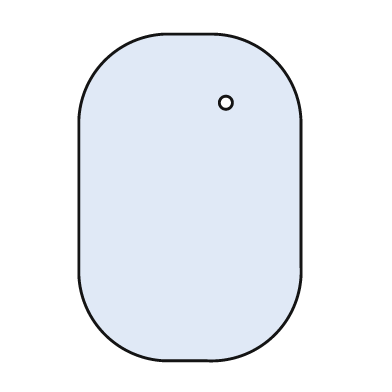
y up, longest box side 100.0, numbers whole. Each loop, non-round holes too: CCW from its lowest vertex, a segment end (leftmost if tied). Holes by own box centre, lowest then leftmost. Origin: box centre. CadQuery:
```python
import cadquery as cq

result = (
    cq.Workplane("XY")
    .moveTo(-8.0, -50.0)
    .lineTo(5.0, -50.0)
    .threePointArc((26.0, -42.0), (34.0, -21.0))
    .lineTo(34.0, 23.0)
    .threePointArc((26.0, 42.0), (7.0, 50.0))
    .lineTo(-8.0, 50.0)
    .threePointArc((-26.0, 42.0), (-34.0, 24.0))
    .lineTo(-34.0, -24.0)
    .threePointArc((-26.0, -42.0), (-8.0, -50.0))
    .close()
    .moveTo(11.0, 29.0)
    .circle(2.0)
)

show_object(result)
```